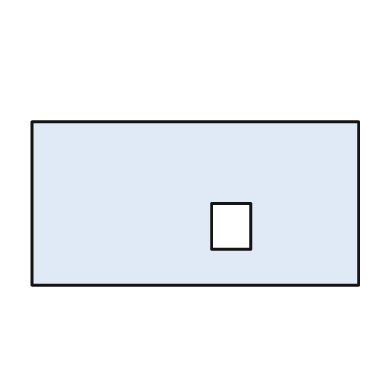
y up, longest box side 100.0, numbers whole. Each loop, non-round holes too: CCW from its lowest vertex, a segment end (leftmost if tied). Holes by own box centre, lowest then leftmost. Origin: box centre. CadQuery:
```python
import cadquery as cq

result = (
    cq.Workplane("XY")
    .moveTo(-50.0, -25.0)
    .lineTo(50.0, -25.0)
    .lineTo(50.0, 25.0)
    .lineTo(-50.0, 25.0)
    .close()
    .moveTo(5.0, -14.0)
    .lineTo(17.0, -14.0)
    .lineTo(17.0, 0.0)
    .lineTo(5.0, 0.0)
    .close()
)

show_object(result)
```